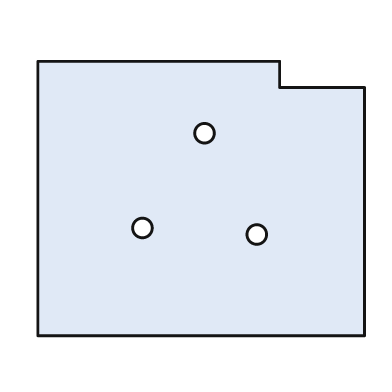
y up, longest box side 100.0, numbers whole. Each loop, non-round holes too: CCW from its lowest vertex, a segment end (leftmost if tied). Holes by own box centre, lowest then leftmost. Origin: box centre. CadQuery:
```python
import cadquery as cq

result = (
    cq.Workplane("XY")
    .moveTo(-50.0, -42.0)
    .lineTo(50.0, -42.0)
    .lineTo(50.0, 34.0)
    .lineTo(24.0, 34.0)
    .lineTo(24.0, 42.0)
    .lineTo(-50.0, 42.0)
    .close()
    .moveTo(17.0, -11.0)
    .circle(3.0)
    .moveTo(-18.0, -9.0)
    .circle(3.0)
    .moveTo(1.0, 20.0)
    .circle(3.0)
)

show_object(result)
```